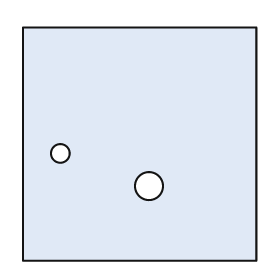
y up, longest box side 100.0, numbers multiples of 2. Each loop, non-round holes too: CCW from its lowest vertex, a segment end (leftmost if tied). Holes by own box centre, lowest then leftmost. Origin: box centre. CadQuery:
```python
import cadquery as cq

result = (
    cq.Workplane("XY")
    .moveTo(-50.0, -50.0)
    .lineTo(50.0, -50.0)
    .lineTo(50.0, 50.0)
    .lineTo(-50.0, 50.0)
    .close()
    .moveTo(4.0, -18.0)
    .circle(6.0)
    .moveTo(-34.0, -4.0)
    .circle(4.0)
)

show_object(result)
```